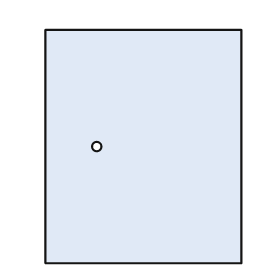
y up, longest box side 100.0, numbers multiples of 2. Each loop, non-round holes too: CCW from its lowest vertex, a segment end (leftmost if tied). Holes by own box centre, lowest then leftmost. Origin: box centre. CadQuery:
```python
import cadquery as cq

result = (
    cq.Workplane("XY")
    .moveTo(-42.0, -50.0)
    .lineTo(42.0, -50.0)
    .lineTo(42.0, 50.0)
    .lineTo(-42.0, 50.0)
    .close()
    .moveTo(-20.0, 0.0)
    .circle(2.0)
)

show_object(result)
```